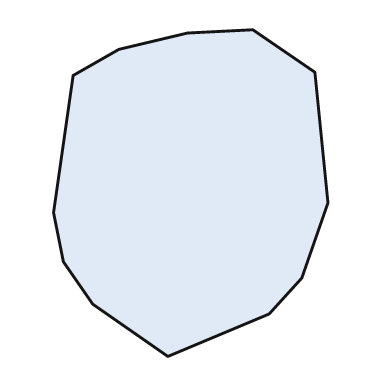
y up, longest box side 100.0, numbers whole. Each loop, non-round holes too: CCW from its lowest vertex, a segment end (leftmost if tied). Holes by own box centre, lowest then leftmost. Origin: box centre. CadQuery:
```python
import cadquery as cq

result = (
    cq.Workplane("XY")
    .moveTo(-7.0, -50.0)
    .lineTo(24.0, -37.0)
    .lineTo(34.0, -26.0)
    .lineTo(42.0, -3.0)
    .lineTo(38.0, 37.0)
    .lineTo(19.0, 50.0)
    .lineTo(-1.0, 49.0)
    .lineTo(-22.0, 44.0)
    .lineTo(-36.0, 36.0)
    .lineTo(-42.0, -6.0)
    .lineTo(-39.0, -21.0)
    .lineTo(-30.0, -34.0)
    .close()
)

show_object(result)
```